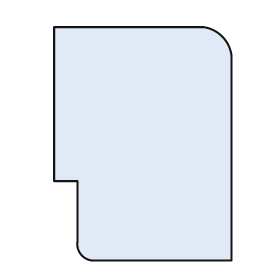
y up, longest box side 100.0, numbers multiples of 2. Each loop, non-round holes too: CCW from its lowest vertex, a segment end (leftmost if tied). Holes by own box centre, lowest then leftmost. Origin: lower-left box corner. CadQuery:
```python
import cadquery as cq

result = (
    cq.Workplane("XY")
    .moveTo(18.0, 0.0)
    .lineTo(76.0, 0.0)
    .lineTo(76.0, 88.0)
    .threePointArc((72.0, 96.0), (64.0, 100.0))
    .lineTo(0.0, 100.0)
    .lineTo(0.0, 34.0)
    .lineTo(10.0, 34.0)
    .lineTo(10.0, 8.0)
    .threePointArc((12.0, 2.0), (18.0, 0.0))
    .close()
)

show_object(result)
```